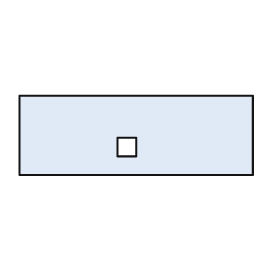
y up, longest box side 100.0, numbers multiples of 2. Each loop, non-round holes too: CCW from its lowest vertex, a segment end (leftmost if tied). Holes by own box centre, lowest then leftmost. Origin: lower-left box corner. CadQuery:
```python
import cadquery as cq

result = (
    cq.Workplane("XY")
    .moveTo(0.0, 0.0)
    .lineTo(100.0, 0.0)
    .lineTo(100.0, 34.0)
    .lineTo(0.0, 34.0)
    .close()
    .moveTo(42.0, 8.0)
    .lineTo(50.0, 8.0)
    .lineTo(50.0, 16.0)
    .lineTo(42.0, 16.0)
    .close()
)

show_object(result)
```